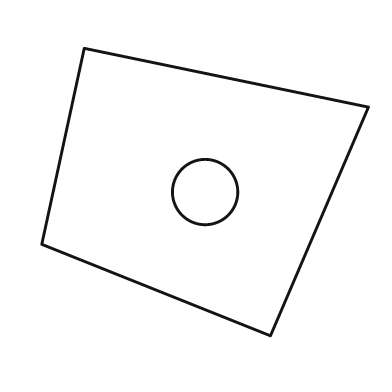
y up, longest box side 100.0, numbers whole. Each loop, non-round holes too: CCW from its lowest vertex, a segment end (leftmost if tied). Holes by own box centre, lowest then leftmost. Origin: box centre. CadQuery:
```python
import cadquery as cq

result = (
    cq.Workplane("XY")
    .moveTo(20.0, -44.0)
    .lineTo(50.0, 26.0)
    .lineTo(-37.0, 44.0)
    .lineTo(-50.0, -16.0)
    .close()
    .moveTo(0.0, 0.0)
    .circle(10.0)
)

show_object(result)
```